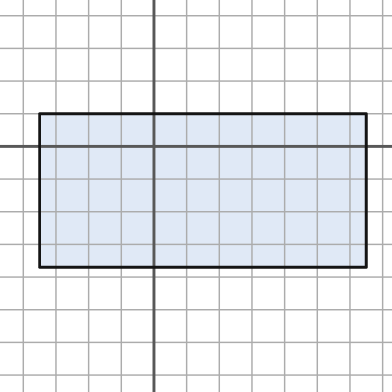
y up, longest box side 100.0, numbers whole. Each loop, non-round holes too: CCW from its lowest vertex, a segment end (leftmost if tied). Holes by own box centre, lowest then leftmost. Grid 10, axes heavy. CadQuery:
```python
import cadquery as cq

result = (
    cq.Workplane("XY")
    .moveTo(-35.0, -37.0)
    .lineTo(65.0, -37.0)
    .lineTo(65.0, 10.0)
    .lineTo(-35.0, 10.0)
    .close()
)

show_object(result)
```